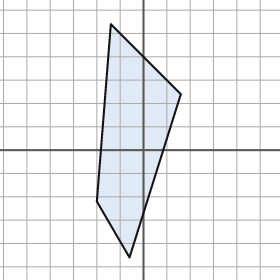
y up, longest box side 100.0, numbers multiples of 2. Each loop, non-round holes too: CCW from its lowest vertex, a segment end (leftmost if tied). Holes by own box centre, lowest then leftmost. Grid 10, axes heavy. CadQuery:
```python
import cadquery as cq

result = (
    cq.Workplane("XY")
    .moveTo(-6.0, -46.0)
    .lineTo(16.0, 24.0)
    .lineTo(-14.0, 54.0)
    .lineTo(-20.0, -22.0)
    .close()
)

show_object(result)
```